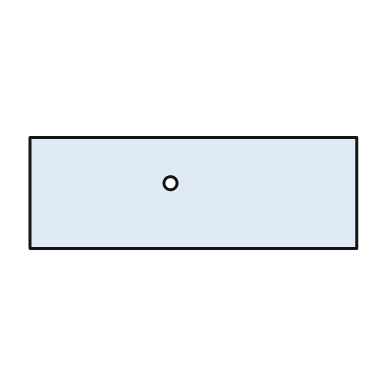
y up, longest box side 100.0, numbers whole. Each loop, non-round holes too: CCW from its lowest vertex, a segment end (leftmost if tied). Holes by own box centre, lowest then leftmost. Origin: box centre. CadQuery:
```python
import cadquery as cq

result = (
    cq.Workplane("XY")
    .moveTo(-50.0, -17.0)
    .lineTo(50.0, -17.0)
    .lineTo(50.0, 17.0)
    .lineTo(-50.0, 17.0)
    .close()
    .moveTo(-7.0, 3.0)
    .circle(2.0)
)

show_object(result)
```